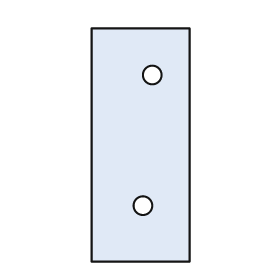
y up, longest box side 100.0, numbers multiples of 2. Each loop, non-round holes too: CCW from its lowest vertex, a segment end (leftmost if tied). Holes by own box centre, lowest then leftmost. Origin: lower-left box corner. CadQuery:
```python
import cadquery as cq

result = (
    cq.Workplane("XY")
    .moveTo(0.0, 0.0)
    .lineTo(42.0, 0.0)
    .lineTo(42.0, 100.0)
    .lineTo(0.0, 100.0)
    .close()
    .moveTo(22.0, 24.0)
    .circle(4.0)
    .moveTo(26.0, 80.0)
    .circle(4.0)
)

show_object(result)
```